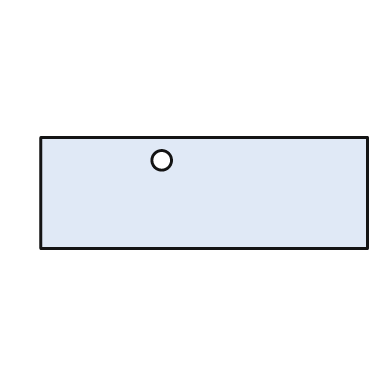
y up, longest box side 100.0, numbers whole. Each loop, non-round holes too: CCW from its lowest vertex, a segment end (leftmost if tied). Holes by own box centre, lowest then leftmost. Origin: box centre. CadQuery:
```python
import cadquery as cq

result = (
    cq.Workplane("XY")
    .moveTo(-50.0, -17.0)
    .lineTo(50.0, -17.0)
    .lineTo(50.0, 17.0)
    .lineTo(-50.0, 17.0)
    .close()
    .moveTo(-13.0, 10.0)
    .circle(3.0)
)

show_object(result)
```